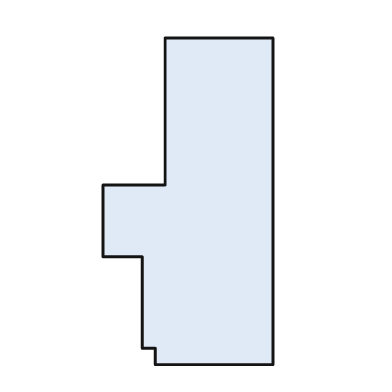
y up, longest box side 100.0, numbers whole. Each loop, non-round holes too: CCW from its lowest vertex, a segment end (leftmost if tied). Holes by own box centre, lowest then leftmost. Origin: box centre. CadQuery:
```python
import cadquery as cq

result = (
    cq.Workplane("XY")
    .moveTo(-10.0, -50.0)
    .lineTo(26.0, -50.0)
    .lineTo(26.0, 50.0)
    .lineTo(-7.0, 50.0)
    .lineTo(-7.0, 5.0)
    .lineTo(-26.0, 5.0)
    .lineTo(-26.0, -17.0)
    .lineTo(-14.0, -17.0)
    .lineTo(-14.0, -45.0)
    .lineTo(-10.0, -45.0)
    .close()
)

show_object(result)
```